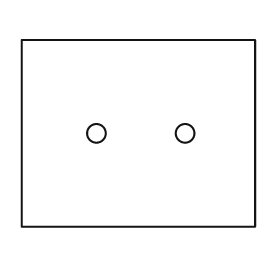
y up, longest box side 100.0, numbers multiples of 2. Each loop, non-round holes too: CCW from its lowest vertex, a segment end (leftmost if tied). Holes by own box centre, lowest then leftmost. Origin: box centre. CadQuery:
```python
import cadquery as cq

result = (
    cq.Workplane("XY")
    .moveTo(-50.0, -40.0)
    .lineTo(50.0, -40.0)
    .lineTo(50.0, 40.0)
    .lineTo(-50.0, 40.0)
    .close()
    .moveTo(-18.0, 0.0)
    .circle(4.0)
    .moveTo(20.0, 0.0)
    .circle(4.0)
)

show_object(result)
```